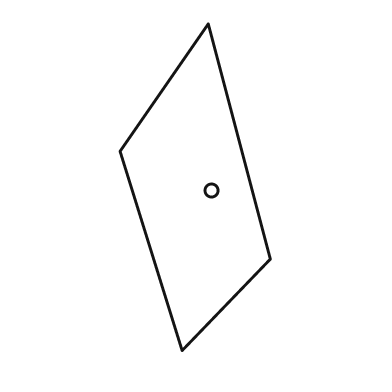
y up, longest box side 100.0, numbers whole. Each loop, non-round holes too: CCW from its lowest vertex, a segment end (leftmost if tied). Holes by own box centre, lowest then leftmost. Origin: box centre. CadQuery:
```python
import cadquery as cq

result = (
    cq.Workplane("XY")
    .moveTo(-4.0, -50.0)
    .lineTo(23.0, -22.0)
    .lineTo(4.0, 50.0)
    .lineTo(-23.0, 11.0)
    .close()
    .moveTo(5.0, -1.0)
    .circle(2.0)
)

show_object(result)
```